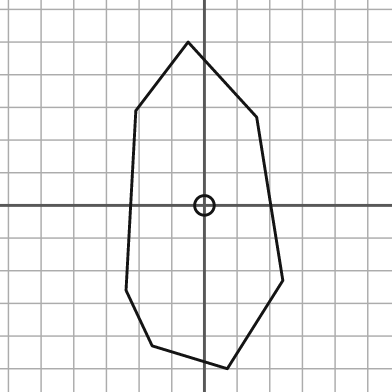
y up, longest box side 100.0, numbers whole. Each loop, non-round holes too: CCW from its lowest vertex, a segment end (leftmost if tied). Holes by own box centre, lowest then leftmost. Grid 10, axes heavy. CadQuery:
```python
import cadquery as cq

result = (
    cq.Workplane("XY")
    .moveTo(7.0, -50.0)
    .lineTo(24.0, -23.0)
    .lineTo(16.0, 27.0)
    .lineTo(-5.0, 50.0)
    .lineTo(-21.0, 29.0)
    .lineTo(-24.0, -26.0)
    .lineTo(-16.0, -43.0)
    .close()
    .moveTo(0.0, 0.0)
    .circle(3.0)
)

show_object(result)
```